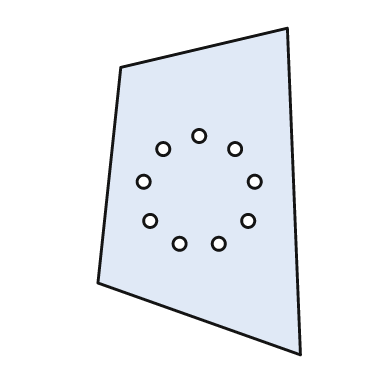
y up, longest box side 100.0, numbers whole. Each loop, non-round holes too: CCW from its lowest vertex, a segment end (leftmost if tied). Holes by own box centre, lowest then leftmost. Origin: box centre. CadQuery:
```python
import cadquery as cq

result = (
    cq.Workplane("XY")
    .moveTo(31.0, -50.0)
    .lineTo(27.0, 50.0)
    .lineTo(-24.0, 38.0)
    .lineTo(-31.0, -28.0)
    .close()
    .moveTo(-6.0, -16.0)
    .circle(2.0)
    .moveTo(6.0, -16.0)
    .circle(2.0)
    .moveTo(-15.0, -9.0)
    .circle(2.0)
    .moveTo(15.0, -9.0)
    .circle(2.0)
    .moveTo(-17.0, 3.0)
    .circle(2.0)
    .moveTo(17.0, 3.0)
    .circle(2.0)
    .moveTo(-11.0, 13.0)
    .circle(2.0)
    .moveTo(11.0, 13.0)
    .circle(2.0)
    .moveTo(0.0, 17.0)
    .circle(2.0)
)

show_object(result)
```